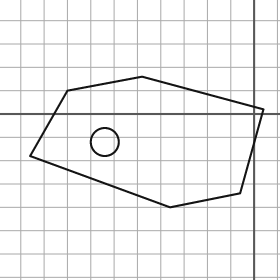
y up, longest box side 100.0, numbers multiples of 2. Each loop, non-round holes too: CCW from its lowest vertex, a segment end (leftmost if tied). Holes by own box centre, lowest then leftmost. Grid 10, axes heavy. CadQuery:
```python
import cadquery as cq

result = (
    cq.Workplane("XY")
    .moveTo(-36.0, -40.0)
    .lineTo(-6.0, -34.0)
    .lineTo(4.0, 2.0)
    .lineTo(-48.0, 16.0)
    .lineTo(-80.0, 10.0)
    .lineTo(-96.0, -18.0)
    .close()
    .moveTo(-64.0, -12.0)
    .circle(6.0)
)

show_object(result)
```